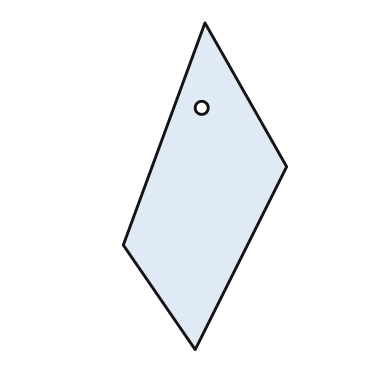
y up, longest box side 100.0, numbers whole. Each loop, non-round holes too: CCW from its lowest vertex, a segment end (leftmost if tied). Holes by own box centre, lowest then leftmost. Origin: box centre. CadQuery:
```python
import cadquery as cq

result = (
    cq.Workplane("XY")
    .moveTo(-3.0, -50.0)
    .lineTo(25.0, 6.0)
    .lineTo(0.0, 50.0)
    .lineTo(-25.0, -18.0)
    .close()
    .moveTo(-1.0, 24.0)
    .circle(2.0)
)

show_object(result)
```